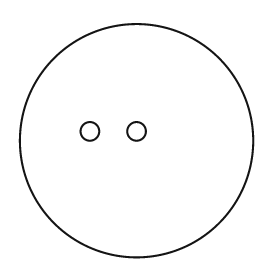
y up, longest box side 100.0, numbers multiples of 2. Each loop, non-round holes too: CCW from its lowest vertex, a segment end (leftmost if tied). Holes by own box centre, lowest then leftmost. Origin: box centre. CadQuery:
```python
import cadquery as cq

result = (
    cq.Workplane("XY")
    .moveTo(0.0, 0.0)
    .circle(50.0)
    .moveTo(-20.0, 4.0)
    .circle(4.0)
    .moveTo(0.0, 4.0)
    .circle(4.0)
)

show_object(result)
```